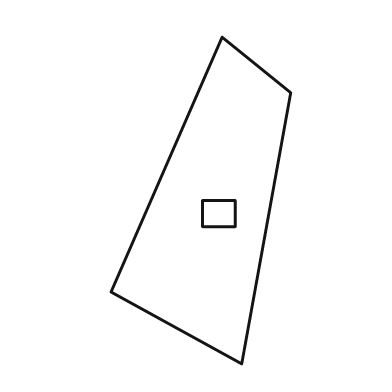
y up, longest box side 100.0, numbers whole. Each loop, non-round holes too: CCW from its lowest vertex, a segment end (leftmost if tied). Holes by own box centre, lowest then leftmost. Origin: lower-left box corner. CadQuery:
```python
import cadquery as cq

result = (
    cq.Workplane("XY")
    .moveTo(40.0, 0.0)
    .lineTo(55.0, 83.0)
    .lineTo(34.0, 100.0)
    .lineTo(0.0, 22.0)
    .close()
    .moveTo(28.0, 42.0)
    .lineTo(38.0, 42.0)
    .lineTo(38.0, 50.0)
    .lineTo(28.0, 50.0)
    .close()
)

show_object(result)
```